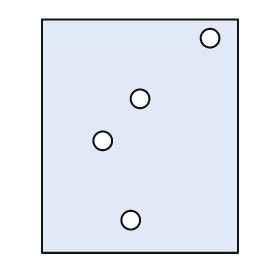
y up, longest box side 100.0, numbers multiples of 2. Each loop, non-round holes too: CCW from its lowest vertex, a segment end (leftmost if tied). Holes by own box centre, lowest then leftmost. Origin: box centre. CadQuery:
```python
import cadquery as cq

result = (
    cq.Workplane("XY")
    .moveTo(-42.0, -50.0)
    .lineTo(42.0, -50.0)
    .lineTo(42.0, 50.0)
    .lineTo(-42.0, 50.0)
    .close()
    .moveTo(-4.0, -36.0)
    .circle(4.0)
    .moveTo(-16.0, -2.0)
    .circle(4.0)
    .moveTo(0.0, 16.0)
    .circle(4.0)
    .moveTo(30.0, 42.0)
    .circle(4.0)
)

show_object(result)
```